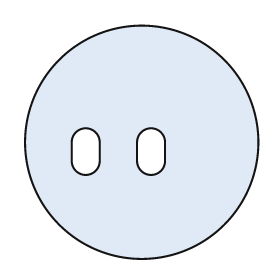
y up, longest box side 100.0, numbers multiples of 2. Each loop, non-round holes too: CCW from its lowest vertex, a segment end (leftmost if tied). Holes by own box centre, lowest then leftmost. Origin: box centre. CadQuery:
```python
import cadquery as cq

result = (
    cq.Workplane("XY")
    .moveTo(0.0, 0.0)
    .circle(50.0)
    .moveTo(-30.0, -8.0)
    .threePointArc((-24.0, -14.0), (-18.0, -8.0))
    .lineTo(-18.0, 0.0)
    .threePointArc((-24.0, 6.0), (-30.0, 0.0))
    .close()
    .moveTo(-2.0, -8.0)
    .threePointArc((4.0, -14.0), (10.0, -8.0))
    .lineTo(10.0, 0.0)
    .threePointArc((4.0, 6.0), (-2.0, 0.0))
    .close()
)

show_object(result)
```